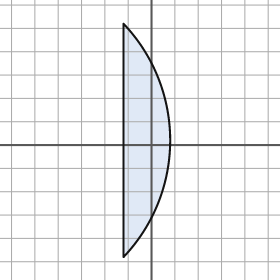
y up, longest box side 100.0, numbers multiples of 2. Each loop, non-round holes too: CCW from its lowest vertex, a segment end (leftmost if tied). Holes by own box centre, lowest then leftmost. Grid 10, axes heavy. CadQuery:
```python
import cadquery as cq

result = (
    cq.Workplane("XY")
    .moveTo(-12.0, -48.0)
    .threePointArc((8.0, 2.0), (-12.0, 52.0))
    .close()
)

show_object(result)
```